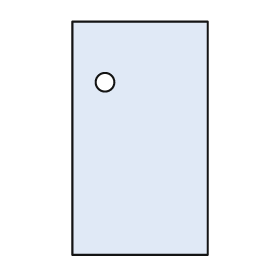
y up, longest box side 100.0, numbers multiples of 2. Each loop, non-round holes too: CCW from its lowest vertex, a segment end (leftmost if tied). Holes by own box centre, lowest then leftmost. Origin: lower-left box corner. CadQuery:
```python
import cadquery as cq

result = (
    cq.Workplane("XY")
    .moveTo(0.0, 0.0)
    .lineTo(58.0, 0.0)
    .lineTo(58.0, 100.0)
    .lineTo(0.0, 100.0)
    .close()
    .moveTo(14.0, 74.0)
    .circle(4.0)
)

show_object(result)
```